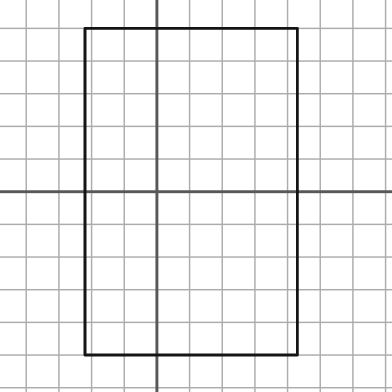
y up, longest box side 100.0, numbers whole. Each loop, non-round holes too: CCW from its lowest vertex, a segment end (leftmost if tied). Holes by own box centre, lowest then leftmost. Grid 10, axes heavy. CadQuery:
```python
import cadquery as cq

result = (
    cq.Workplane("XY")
    .moveTo(-22.0, -50.0)
    .lineTo(43.0, -50.0)
    .lineTo(43.0, 50.0)
    .lineTo(-22.0, 50.0)
    .close()
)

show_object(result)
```